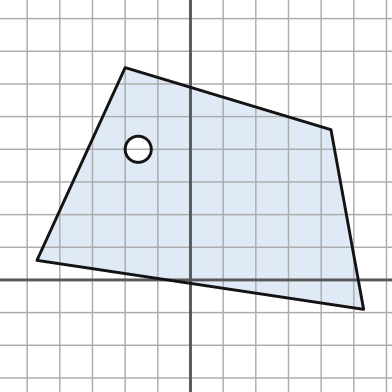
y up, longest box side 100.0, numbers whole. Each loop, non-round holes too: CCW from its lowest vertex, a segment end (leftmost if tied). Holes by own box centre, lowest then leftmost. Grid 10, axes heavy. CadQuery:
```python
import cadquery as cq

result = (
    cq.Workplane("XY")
    .moveTo(53.0, -9.0)
    .lineTo(43.0, 46.0)
    .lineTo(-20.0, 65.0)
    .lineTo(-47.0, 6.0)
    .close()
    .moveTo(-16.0, 40.0)
    .circle(4.0)
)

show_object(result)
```